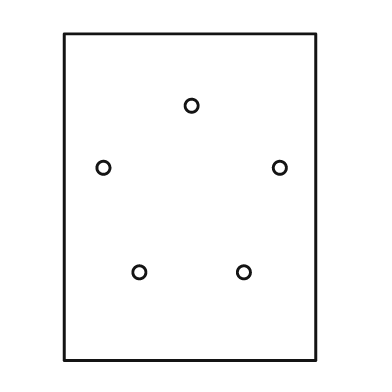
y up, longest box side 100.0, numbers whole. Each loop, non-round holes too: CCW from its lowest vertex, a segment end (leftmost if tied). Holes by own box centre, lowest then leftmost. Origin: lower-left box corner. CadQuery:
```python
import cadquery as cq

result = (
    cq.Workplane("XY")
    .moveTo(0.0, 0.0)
    .lineTo(77.0, 0.0)
    .lineTo(77.0, 100.0)
    .lineTo(0.0, 100.0)
    .close()
    .moveTo(23.0, 27.0)
    .circle(2.0)
    .moveTo(55.0, 27.0)
    .circle(2.0)
    .moveTo(12.0, 59.0)
    .circle(2.0)
    .moveTo(66.0, 59.0)
    .circle(2.0)
    .moveTo(39.0, 78.0)
    .circle(2.0)
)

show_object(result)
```